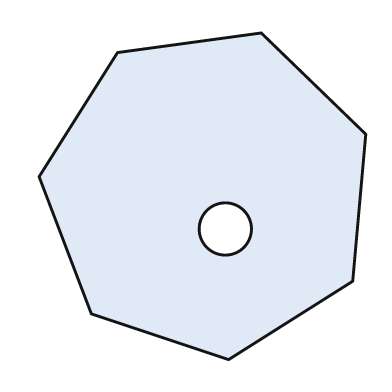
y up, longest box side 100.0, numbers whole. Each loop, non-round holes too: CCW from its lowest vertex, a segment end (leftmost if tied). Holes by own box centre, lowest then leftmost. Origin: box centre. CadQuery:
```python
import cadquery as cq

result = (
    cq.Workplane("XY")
    .moveTo(8.0, -50.0)
    .lineTo(46.0, -26.0)
    .lineTo(50.0, 19.0)
    .lineTo(18.0, 50.0)
    .lineTo(-26.0, 44.0)
    .lineTo(-50.0, 6.0)
    .lineTo(-34.0, -36.0)
    .close()
    .moveTo(7.0, -10.0)
    .circle(8.0)
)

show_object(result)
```